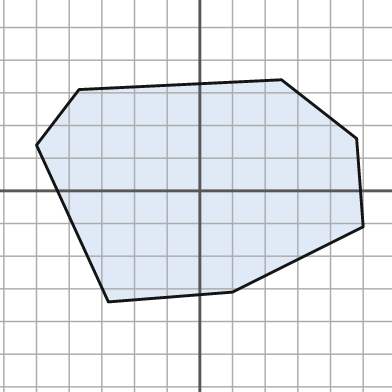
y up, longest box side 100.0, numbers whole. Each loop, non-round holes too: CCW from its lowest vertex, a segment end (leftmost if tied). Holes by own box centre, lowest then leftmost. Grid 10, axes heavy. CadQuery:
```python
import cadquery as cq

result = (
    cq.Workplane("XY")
    .moveTo(-28.0, -34.0)
    .lineTo(10.0, -31.0)
    .lineTo(50.0, -11.0)
    .lineTo(48.0, 16.0)
    .lineTo(25.0, 34.0)
    .lineTo(-37.0, 31.0)
    .lineTo(-50.0, 14.0)
    .close()
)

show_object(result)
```